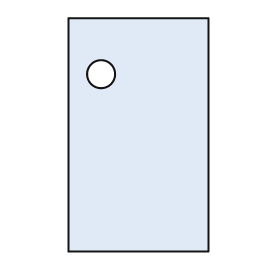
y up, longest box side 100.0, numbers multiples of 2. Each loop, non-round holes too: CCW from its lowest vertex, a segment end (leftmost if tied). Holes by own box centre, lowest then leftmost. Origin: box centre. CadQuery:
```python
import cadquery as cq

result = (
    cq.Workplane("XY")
    .moveTo(-30.0, -50.0)
    .lineTo(30.0, -50.0)
    .lineTo(30.0, 50.0)
    .lineTo(-30.0, 50.0)
    .close()
    .moveTo(-16.0, 26.0)
    .circle(6.0)
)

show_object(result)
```